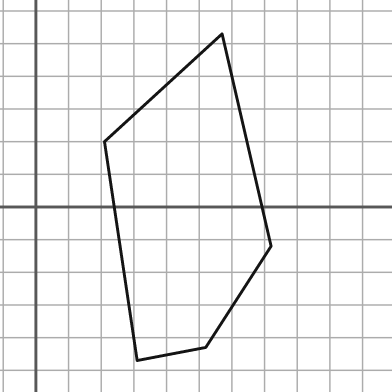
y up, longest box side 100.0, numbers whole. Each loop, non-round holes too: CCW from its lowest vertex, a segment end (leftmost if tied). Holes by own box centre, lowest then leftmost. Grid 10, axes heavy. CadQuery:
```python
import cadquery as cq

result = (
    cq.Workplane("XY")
    .moveTo(31.0, -47.0)
    .lineTo(52.0, -43.0)
    .lineTo(72.0, -12.0)
    .lineTo(57.0, 53.0)
    .lineTo(21.0, 20.0)
    .close()
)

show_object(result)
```